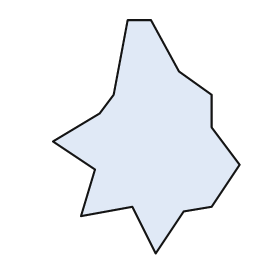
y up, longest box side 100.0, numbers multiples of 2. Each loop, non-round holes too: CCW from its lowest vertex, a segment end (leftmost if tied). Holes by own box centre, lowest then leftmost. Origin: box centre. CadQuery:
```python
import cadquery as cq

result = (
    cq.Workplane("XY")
    .moveTo(4.0, -50.0)
    .lineTo(16.0, -32.0)
    .lineTo(28.0, -30.0)
    .lineTo(40.0, -12.0)
    .lineTo(28.0, 4.0)
    .lineTo(28.0, 18.0)
    .lineTo(14.0, 28.0)
    .lineTo(2.0, 50.0)
    .lineTo(-8.0, 50.0)
    .lineTo(-14.0, 18.0)
    .lineTo(-20.0, 10.0)
    .lineTo(-40.0, -2.0)
    .lineTo(-22.0, -14.0)
    .lineTo(-28.0, -34.0)
    .lineTo(-6.0, -30.0)
    .close()
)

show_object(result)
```